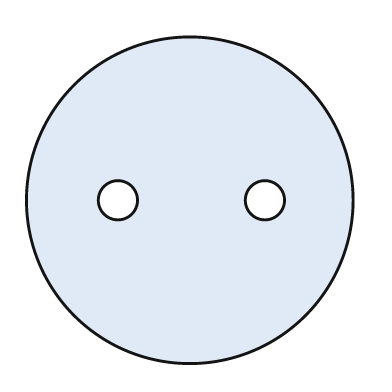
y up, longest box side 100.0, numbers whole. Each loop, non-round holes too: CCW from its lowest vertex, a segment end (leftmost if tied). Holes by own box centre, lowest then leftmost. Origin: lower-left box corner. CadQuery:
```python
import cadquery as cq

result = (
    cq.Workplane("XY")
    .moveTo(50.0, 50.0)
    .circle(50.0)
    .moveTo(28.0, 50.0)
    .circle(6.0)
    .moveTo(73.0, 50.0)
    .circle(6.0)
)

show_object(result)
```